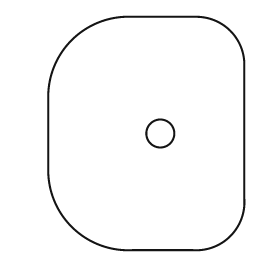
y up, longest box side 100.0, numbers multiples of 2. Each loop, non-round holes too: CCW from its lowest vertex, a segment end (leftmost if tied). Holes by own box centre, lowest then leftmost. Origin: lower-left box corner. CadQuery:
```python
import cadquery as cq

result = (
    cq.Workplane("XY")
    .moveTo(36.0, 0.0)
    .lineTo(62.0, 0.0)
    .threePointArc((78.0, 6.0), (84.0, 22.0))
    .lineTo(84.0, 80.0)
    .threePointArc((78.0, 94.0), (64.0, 100.0))
    .lineTo(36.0, 100.0)
    .threePointArc((10.0, 90.0), (0.0, 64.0))
    .lineTo(0.0, 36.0)
    .threePointArc((10.0, 10.0), (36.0, 0.0))
    .close()
    .moveTo(48.0, 50.0)
    .circle(6.0)
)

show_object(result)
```